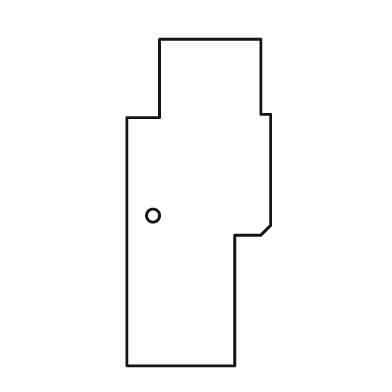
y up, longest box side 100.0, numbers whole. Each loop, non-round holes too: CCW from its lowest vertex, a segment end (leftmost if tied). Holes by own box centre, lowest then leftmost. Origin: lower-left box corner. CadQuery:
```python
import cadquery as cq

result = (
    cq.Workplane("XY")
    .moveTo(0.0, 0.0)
    .lineTo(33.0, 0.0)
    .lineTo(33.0, 40.0)
    .lineTo(41.0, 40.0)
    .lineTo(44.0, 43.0)
    .lineTo(44.0, 77.0)
    .lineTo(41.0, 77.0)
    .lineTo(41.0, 100.0)
    .lineTo(10.0, 100.0)
    .lineTo(10.0, 76.0)
    .lineTo(0.0, 76.0)
    .close()
    .moveTo(8.0, 46.0)
    .circle(2.0)
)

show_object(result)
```